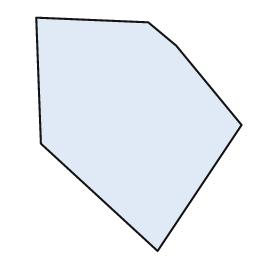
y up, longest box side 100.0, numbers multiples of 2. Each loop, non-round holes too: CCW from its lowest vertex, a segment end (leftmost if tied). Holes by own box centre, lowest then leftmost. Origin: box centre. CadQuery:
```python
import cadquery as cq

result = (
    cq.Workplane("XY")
    .moveTo(8.0, -50.0)
    .lineTo(44.0, 4.0)
    .lineTo(16.0, 38.0)
    .lineTo(4.0, 48.0)
    .lineTo(-44.0, 50.0)
    .lineTo(-42.0, -4.0)
    .close()
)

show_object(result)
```